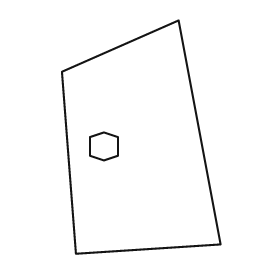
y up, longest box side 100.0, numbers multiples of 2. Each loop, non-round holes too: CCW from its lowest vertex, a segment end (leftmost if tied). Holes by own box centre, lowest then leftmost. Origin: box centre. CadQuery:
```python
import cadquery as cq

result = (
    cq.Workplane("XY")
    .moveTo(-28.0, -50.0)
    .lineTo(34.0, -46.0)
    .lineTo(16.0, 50.0)
    .lineTo(-34.0, 28.0)
    .close()
    .moveTo(-16.0, -10.0)
    .lineTo(-10.0, -8.0)
    .lineTo(-10.0, 0.0)
    .lineTo(-16.0, 2.0)
    .lineTo(-22.0, 0.0)
    .lineTo(-22.0, -8.0)
    .close()
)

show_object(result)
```